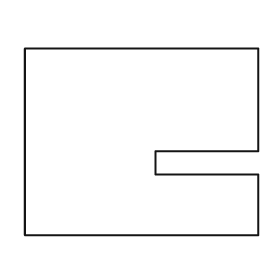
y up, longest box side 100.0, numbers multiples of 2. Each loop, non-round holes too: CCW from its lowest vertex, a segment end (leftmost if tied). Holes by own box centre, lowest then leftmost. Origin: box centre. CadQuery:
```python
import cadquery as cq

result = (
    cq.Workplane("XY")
    .moveTo(-50.0, -40.0)
    .lineTo(50.0, -40.0)
    .lineTo(50.0, -14.0)
    .lineTo(6.0, -14.0)
    .lineTo(6.0, -4.0)
    .lineTo(50.0, -4.0)
    .lineTo(50.0, 40.0)
    .lineTo(-50.0, 40.0)
    .close()
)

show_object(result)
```